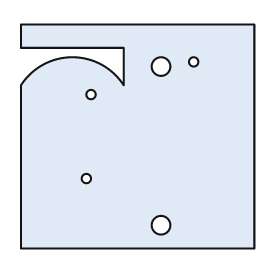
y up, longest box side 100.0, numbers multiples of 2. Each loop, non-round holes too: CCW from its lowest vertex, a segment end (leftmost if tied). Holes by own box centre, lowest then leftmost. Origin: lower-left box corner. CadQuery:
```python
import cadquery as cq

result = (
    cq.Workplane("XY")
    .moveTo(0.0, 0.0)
    .lineTo(100.0, 0.0)
    .lineTo(100.0, 96.0)
    .lineTo(0.0, 96.0)
    .lineTo(0.0, 86.0)
    .lineTo(44.0, 86.0)
    .lineTo(44.0, 70.0)
    .threePointArc((22.0, 82.0), (0.0, 70.0))
    .close()
    .moveTo(60.0, 10.0)
    .circle(4.0)
    .moveTo(28.0, 30.0)
    .circle(2.0)
    .moveTo(30.0, 66.0)
    .circle(2.0)
    .moveTo(60.0, 78.0)
    .circle(4.0)
    .moveTo(74.0, 80.0)
    .circle(2.0)
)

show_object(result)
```